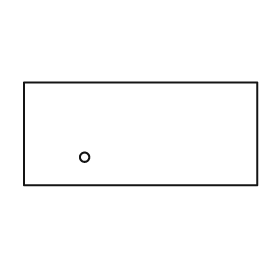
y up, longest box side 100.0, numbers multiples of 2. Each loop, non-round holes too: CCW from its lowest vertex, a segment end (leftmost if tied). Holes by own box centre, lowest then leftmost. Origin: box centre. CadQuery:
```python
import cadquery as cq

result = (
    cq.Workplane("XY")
    .moveTo(-50.0, -22.0)
    .lineTo(50.0, -22.0)
    .lineTo(50.0, 22.0)
    .lineTo(-50.0, 22.0)
    .close()
    .moveTo(-24.0, -10.0)
    .circle(2.0)
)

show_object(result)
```